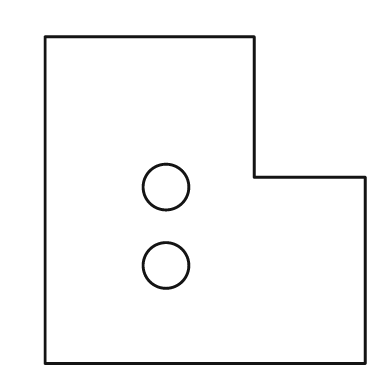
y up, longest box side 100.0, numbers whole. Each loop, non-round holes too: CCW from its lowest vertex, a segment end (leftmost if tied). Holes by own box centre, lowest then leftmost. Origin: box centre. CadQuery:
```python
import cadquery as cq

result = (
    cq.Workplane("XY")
    .moveTo(-49.0, -50.0)
    .lineTo(49.0, -50.0)
    .lineTo(49.0, 7.0)
    .lineTo(15.0, 7.0)
    .lineTo(15.0, 50.0)
    .lineTo(-49.0, 50.0)
    .close()
    .moveTo(-12.0, -20.0)
    .circle(7.0)
    .moveTo(-12.0, 4.0)
    .circle(7.0)
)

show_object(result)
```